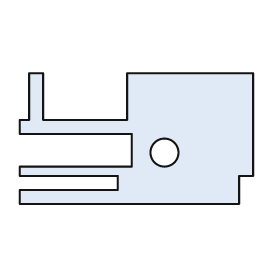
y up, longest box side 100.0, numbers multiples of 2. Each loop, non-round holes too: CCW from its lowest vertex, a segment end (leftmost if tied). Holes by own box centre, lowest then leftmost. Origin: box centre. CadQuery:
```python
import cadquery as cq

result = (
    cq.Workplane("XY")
    .moveTo(-50.0, -28.0)
    .lineTo(44.0, -28.0)
    .lineTo(44.0, -16.0)
    .lineTo(50.0, -16.0)
    .lineTo(50.0, 28.0)
    .lineTo(-4.0, 28.0)
    .lineTo(-4.0, 8.0)
    .lineTo(-40.0, 8.0)
    .lineTo(-40.0, 28.0)
    .lineTo(-46.0, 28.0)
    .lineTo(-46.0, 8.0)
    .lineTo(-50.0, 8.0)
    .lineTo(-50.0, 2.0)
    .lineTo(-2.0, 2.0)
    .lineTo(-2.0, -12.0)
    .lineTo(-50.0, -12.0)
    .lineTo(-50.0, -16.0)
    .lineTo(-8.0, -16.0)
    .lineTo(-8.0, -22.0)
    .lineTo(-50.0, -22.0)
    .close()
    .moveTo(12.0, -6.0)
    .circle(6.0)
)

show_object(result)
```